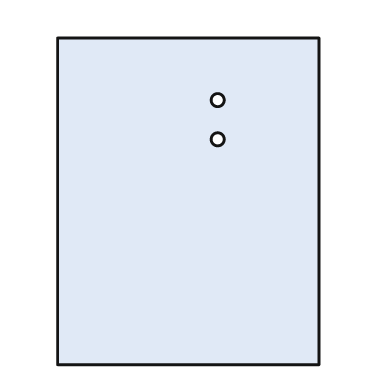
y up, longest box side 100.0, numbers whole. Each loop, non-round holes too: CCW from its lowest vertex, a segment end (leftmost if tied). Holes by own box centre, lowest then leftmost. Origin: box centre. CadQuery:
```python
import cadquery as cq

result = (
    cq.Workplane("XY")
    .moveTo(-40.0, -50.0)
    .lineTo(40.0, -50.0)
    .lineTo(40.0, 50.0)
    .lineTo(-40.0, 50.0)
    .close()
    .moveTo(9.0, 19.0)
    .circle(2.0)
    .moveTo(9.0, 31.0)
    .circle(2.0)
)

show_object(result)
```